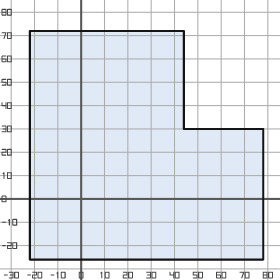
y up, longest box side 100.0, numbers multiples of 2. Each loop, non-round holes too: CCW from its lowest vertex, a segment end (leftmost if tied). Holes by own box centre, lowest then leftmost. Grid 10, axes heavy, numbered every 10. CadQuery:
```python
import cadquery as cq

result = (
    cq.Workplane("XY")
    .moveTo(-22.0, -26.0)
    .lineTo(78.0, -26.0)
    .lineTo(78.0, 30.0)
    .lineTo(44.0, 30.0)
    .lineTo(44.0, 72.0)
    .lineTo(-22.0, 72.0)
    .close()
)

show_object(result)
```